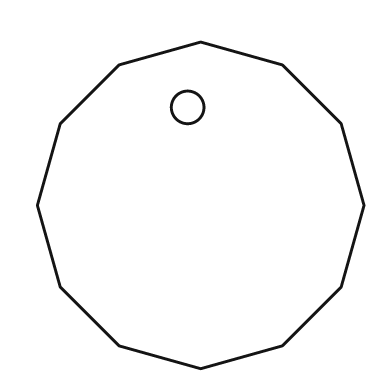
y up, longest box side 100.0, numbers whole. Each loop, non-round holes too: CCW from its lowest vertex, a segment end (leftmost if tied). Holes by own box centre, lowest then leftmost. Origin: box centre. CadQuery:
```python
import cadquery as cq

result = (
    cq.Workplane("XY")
    .moveTo(0.0, -50.0)
    .lineTo(25.0, -43.0)
    .lineTo(43.0, -25.0)
    .lineTo(50.0, 0.0)
    .lineTo(43.0, 25.0)
    .lineTo(25.0, 43.0)
    .lineTo(0.0, 50.0)
    .lineTo(-25.0, 43.0)
    .lineTo(-43.0, 25.0)
    .lineTo(-50.0, 0.0)
    .lineTo(-43.0, -25.0)
    .lineTo(-25.0, -43.0)
    .close()
    .moveTo(-4.0, 30.0)
    .circle(5.0)
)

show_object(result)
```